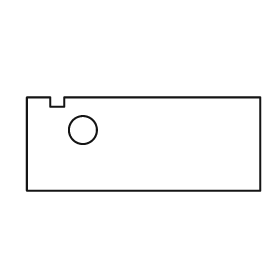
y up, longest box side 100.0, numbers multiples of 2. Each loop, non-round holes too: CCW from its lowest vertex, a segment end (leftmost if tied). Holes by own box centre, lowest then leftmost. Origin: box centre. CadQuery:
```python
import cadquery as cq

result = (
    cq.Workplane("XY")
    .moveTo(-50.0, -20.0)
    .lineTo(50.0, -20.0)
    .lineTo(50.0, 20.0)
    .lineTo(-34.0, 20.0)
    .lineTo(-34.0, 16.0)
    .lineTo(-40.0, 16.0)
    .lineTo(-40.0, 20.0)
    .lineTo(-50.0, 20.0)
    .close()
    .moveTo(-26.0, 6.0)
    .circle(6.0)
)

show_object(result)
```